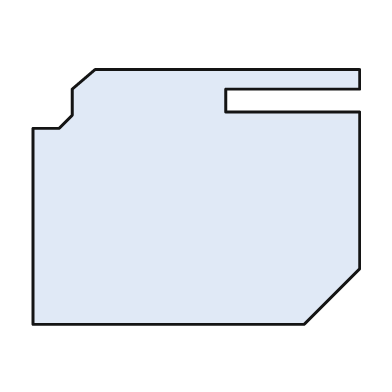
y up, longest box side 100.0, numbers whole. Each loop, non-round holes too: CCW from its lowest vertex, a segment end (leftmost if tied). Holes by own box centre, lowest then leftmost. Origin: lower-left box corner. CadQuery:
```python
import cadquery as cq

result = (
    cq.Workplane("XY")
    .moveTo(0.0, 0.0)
    .lineTo(83.0, 0.0)
    .lineTo(100.0, 17.0)
    .lineTo(100.0, 65.0)
    .lineTo(59.0, 65.0)
    .lineTo(59.0, 72.0)
    .lineTo(100.0, 72.0)
    .lineTo(100.0, 78.0)
    .lineTo(19.0, 78.0)
    .lineTo(12.0, 72.0)
    .lineTo(12.0, 64.0)
    .lineTo(8.0, 60.0)
    .lineTo(0.0, 60.0)
    .close()
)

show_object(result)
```